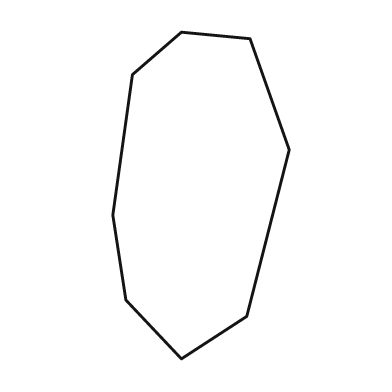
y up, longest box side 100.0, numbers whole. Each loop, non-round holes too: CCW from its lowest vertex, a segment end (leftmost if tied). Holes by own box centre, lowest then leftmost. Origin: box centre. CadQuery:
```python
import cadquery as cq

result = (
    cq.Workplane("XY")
    .moveTo(-6.0, -50.0)
    .lineTo(14.0, -37.0)
    .lineTo(27.0, 14.0)
    .lineTo(15.0, 48.0)
    .lineTo(-6.0, 50.0)
    .lineTo(-21.0, 37.0)
    .lineTo(-27.0, -6.0)
    .lineTo(-23.0, -32.0)
    .close()
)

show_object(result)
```